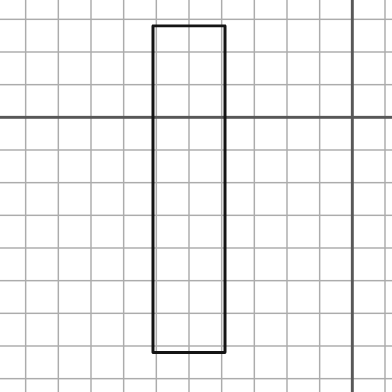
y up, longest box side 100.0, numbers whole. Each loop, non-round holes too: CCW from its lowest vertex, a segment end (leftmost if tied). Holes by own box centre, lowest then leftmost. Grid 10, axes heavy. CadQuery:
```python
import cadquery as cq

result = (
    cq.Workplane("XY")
    .moveTo(-61.0, -72.0)
    .lineTo(-39.0, -72.0)
    .lineTo(-39.0, 28.0)
    .lineTo(-61.0, 28.0)
    .close()
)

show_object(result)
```